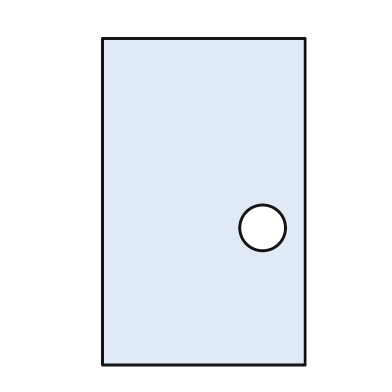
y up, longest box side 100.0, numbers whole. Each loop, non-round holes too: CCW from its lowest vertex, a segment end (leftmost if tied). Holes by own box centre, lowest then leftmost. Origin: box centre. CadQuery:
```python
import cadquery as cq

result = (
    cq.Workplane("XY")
    .moveTo(-31.0, -50.0)
    .lineTo(31.0, -50.0)
    .lineTo(31.0, 50.0)
    .lineTo(-31.0, 50.0)
    .close()
    .moveTo(18.0, -8.0)
    .circle(7.0)
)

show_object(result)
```